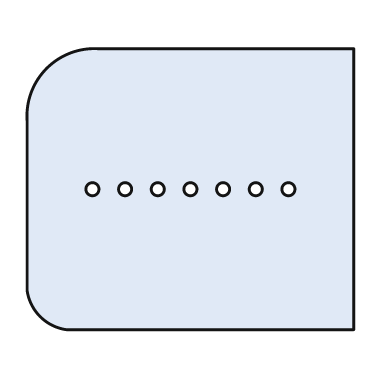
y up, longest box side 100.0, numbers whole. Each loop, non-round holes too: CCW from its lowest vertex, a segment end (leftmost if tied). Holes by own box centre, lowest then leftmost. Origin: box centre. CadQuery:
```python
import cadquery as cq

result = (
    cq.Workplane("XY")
    .moveTo(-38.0, -43.0)
    .lineTo(50.0, -43.0)
    .lineTo(50.0, 43.0)
    .lineTo(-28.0, 43.0)
    .threePointArc((-44.0, 37.0), (-50.0, 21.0))
    .lineTo(-50.0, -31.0)
    .threePointArc((-46.0, -39.0), (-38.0, -43.0))
    .close()
    .moveTo(-30.0, 0.0)
    .circle(2.0)
    .moveTo(-20.0, 0.0)
    .circle(2.0)
    .moveTo(-10.0, 0.0)
    .circle(2.0)
    .moveTo(0.0, 0.0)
    .circle(2.0)
    .moveTo(10.0, 0.0)
    .circle(2.0)
    .moveTo(20.0, 0.0)
    .circle(2.0)
    .moveTo(30.0, 0.0)
    .circle(2.0)
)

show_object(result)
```